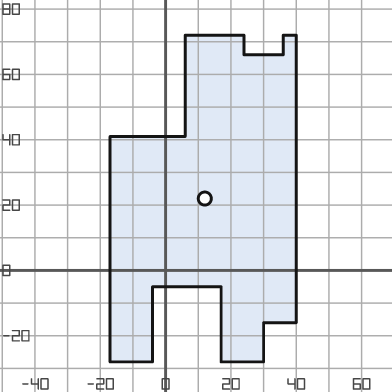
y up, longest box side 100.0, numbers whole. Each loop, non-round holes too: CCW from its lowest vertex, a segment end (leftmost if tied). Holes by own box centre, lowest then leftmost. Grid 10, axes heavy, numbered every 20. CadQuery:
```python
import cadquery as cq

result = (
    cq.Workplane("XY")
    .moveTo(-17.0, -28.0)
    .lineTo(-4.0, -28.0)
    .lineTo(-4.0, -5.0)
    .lineTo(17.0, -5.0)
    .lineTo(17.0, -28.0)
    .lineTo(30.0, -28.0)
    .lineTo(30.0, -16.0)
    .lineTo(40.0, -16.0)
    .lineTo(40.0, 72.0)
    .lineTo(36.0, 72.0)
    .lineTo(36.0, 66.0)
    .lineTo(24.0, 66.0)
    .lineTo(24.0, 72.0)
    .lineTo(6.0, 72.0)
    .lineTo(6.0, 41.0)
    .lineTo(-17.0, 41.0)
    .close()
    .moveTo(12.0, 22.0)
    .circle(2.0)
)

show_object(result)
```